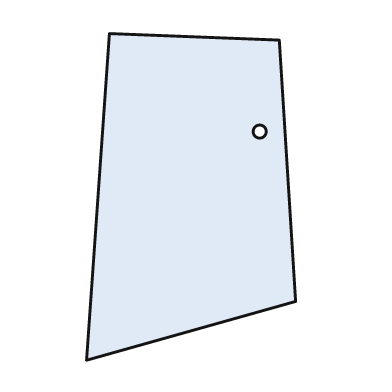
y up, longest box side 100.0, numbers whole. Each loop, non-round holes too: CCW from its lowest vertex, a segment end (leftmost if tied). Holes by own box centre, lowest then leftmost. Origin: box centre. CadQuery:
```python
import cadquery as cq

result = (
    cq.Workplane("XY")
    .moveTo(-32.0, -50.0)
    .lineTo(32.0, -32.0)
    .lineTo(27.0, 48.0)
    .lineTo(-25.0, 50.0)
    .close()
    .moveTo(21.0, 20.0)
    .circle(2.0)
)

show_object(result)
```